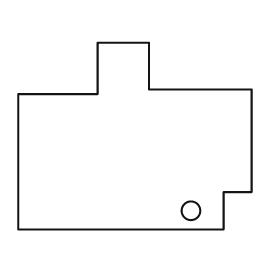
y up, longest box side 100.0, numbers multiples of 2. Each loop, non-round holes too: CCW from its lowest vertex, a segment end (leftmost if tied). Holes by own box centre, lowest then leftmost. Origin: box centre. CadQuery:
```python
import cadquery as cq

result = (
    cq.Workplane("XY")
    .moveTo(-50.0, -40.0)
    .lineTo(38.0, -40.0)
    .lineTo(38.0, -24.0)
    .lineTo(50.0, -24.0)
    .lineTo(50.0, 20.0)
    .lineTo(6.0, 20.0)
    .lineTo(6.0, 40.0)
    .lineTo(-16.0, 40.0)
    .lineTo(-16.0, 18.0)
    .lineTo(-50.0, 18.0)
    .close()
    .moveTo(24.0, -32.0)
    .circle(4.0)
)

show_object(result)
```